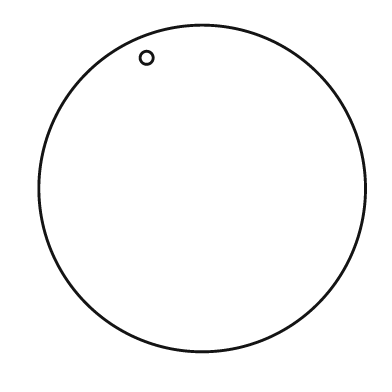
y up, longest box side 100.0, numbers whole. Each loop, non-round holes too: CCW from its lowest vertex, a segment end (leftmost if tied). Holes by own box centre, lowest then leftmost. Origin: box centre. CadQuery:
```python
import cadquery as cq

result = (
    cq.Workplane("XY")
    .moveTo(0.0, 0.0)
    .circle(50.0)
    .moveTo(-17.0, 40.0)
    .circle(2.0)
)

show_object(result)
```